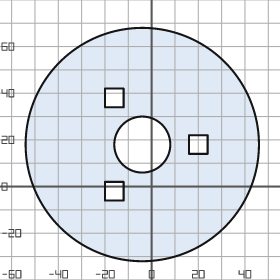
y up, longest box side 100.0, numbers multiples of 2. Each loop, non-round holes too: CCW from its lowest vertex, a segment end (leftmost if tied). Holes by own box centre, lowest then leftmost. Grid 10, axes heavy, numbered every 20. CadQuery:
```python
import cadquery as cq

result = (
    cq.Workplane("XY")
    .moveTo(-4.0, 18.0)
    .circle(50.0)
    .moveTo(-20.0, -6.0)
    .lineTo(-12.0, -6.0)
    .lineTo(-12.0, 2.0)
    .lineTo(-20.0, 2.0)
    .close()
    .moveTo(-4.0, 18.0)
    .circle(12.0)
    .moveTo(16.0, 14.0)
    .lineTo(24.0, 14.0)
    .lineTo(24.0, 22.0)
    .lineTo(16.0, 22.0)
    .close()
    .moveTo(-20.0, 34.0)
    .lineTo(-12.0, 34.0)
    .lineTo(-12.0, 42.0)
    .lineTo(-20.0, 42.0)
    .close()
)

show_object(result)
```